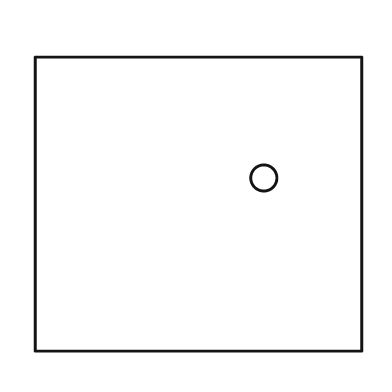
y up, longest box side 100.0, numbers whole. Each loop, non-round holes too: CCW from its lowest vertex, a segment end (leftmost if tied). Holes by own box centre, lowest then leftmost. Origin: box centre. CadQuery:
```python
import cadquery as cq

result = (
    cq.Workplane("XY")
    .moveTo(-50.0, -45.0)
    .lineTo(50.0, -45.0)
    .lineTo(50.0, 45.0)
    .lineTo(-50.0, 45.0)
    .close()
    .moveTo(20.0, 8.0)
    .circle(4.0)
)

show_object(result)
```